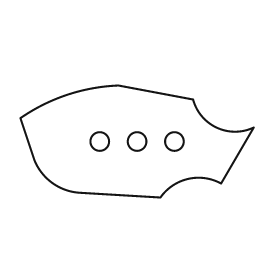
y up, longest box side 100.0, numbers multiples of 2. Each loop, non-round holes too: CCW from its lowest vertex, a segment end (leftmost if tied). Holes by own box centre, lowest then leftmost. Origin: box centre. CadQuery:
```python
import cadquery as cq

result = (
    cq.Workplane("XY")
    .moveTo(10.0, -24.0)
    .threePointArc((22.0, -16.0), (36.0, -18.0))
    .lineTo(50.0, 6.0)
    .threePointArc((34.0, 6.0), (24.0, 18.0))
    .lineTo(-8.0, 24.0)
    .threePointArc((-30.0, 20.0), (-50.0, 10.0))
    .lineTo(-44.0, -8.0)
    .threePointArc((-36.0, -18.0), (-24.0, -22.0))
    .close()
    .moveTo(-16.0, 0.0)
    .circle(4.0)
    .moveTo(0.0, 0.0)
    .circle(4.0)
    .moveTo(16.0, 0.0)
    .circle(4.0)
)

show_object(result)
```